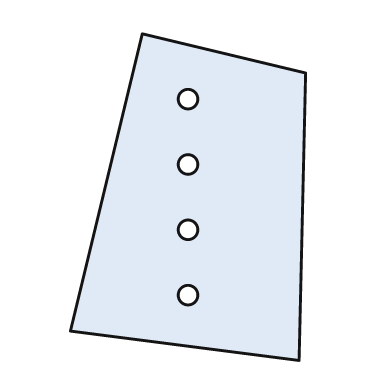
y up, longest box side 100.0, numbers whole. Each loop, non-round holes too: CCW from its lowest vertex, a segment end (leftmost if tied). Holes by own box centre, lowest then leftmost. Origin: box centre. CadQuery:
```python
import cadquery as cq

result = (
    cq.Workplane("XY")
    .moveTo(34.0, -50.0)
    .lineTo(36.0, 38.0)
    .lineTo(-14.0, 50.0)
    .lineTo(-36.0, -41.0)
    .close()
    .moveTo(0.0, -30.0)
    .circle(3.0)
    .moveTo(0.0, -10.0)
    .circle(3.0)
    .moveTo(0.0, 10.0)
    .circle(3.0)
    .moveTo(0.0, 30.0)
    .circle(3.0)
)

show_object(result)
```